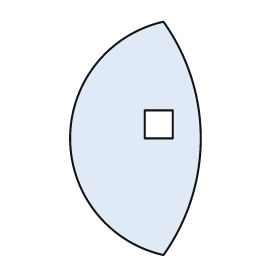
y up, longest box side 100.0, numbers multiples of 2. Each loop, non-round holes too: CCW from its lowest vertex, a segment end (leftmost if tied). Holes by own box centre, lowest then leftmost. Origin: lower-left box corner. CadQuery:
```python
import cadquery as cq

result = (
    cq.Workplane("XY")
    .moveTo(40.0, 0.0)
    .threePointArc((56.0, 50.0), (40.0, 100.0))
    .threePointArc((0.0, 50.0), (40.0, 0.0))
    .close()
    .moveTo(32.0, 50.0)
    .lineTo(44.0, 50.0)
    .lineTo(44.0, 62.0)
    .lineTo(32.0, 62.0)
    .close()
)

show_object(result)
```